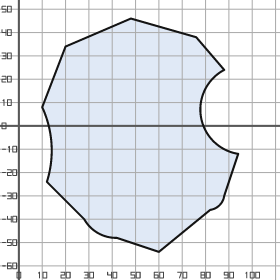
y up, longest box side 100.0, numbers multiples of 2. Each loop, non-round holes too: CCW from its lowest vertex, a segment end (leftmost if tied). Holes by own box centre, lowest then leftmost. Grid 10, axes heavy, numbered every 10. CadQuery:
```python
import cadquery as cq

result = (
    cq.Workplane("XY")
    .moveTo(60.0, -54.0)
    .lineTo(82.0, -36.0)
    .threePointArc((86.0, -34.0), (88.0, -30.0))
    .lineTo(94.0, -12.0)
    .threePointArc((78.0, 4.0), (88.0, 24.0))
    .lineTo(76.0, 38.0)
    .lineTo(48.0, 46.0)
    .lineTo(20.0, 34.0)
    .lineTo(10.0, 8.0)
    .threePointArc((14.0, -8.0), (12.0, -24.0))
    .lineTo(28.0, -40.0)
    .threePointArc((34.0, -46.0), (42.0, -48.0))
    .close()
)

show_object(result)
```